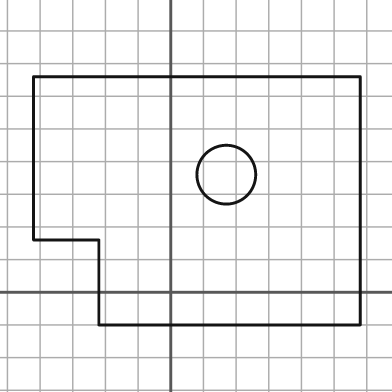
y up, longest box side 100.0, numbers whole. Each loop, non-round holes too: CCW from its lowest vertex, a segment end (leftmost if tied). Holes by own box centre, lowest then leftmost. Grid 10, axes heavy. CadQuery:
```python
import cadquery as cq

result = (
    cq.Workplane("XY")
    .moveTo(-22.0, -10.0)
    .lineTo(58.0, -10.0)
    .lineTo(58.0, 66.0)
    .lineTo(-42.0, 66.0)
    .lineTo(-42.0, 16.0)
    .lineTo(-22.0, 16.0)
    .close()
    .moveTo(17.0, 36.0)
    .circle(9.0)
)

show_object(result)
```